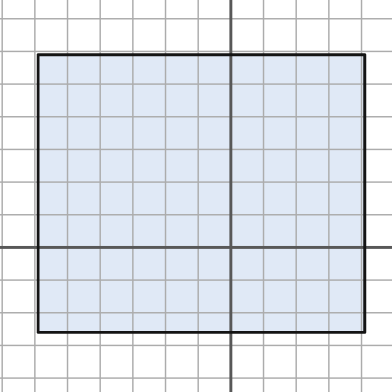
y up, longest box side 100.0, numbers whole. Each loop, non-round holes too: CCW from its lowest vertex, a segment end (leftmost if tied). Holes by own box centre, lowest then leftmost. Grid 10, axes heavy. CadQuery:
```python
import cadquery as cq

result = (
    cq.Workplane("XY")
    .moveTo(-59.0, -26.0)
    .lineTo(41.0, -26.0)
    .lineTo(41.0, 59.0)
    .lineTo(-59.0, 59.0)
    .close()
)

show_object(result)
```